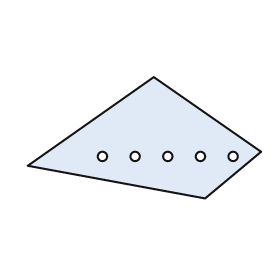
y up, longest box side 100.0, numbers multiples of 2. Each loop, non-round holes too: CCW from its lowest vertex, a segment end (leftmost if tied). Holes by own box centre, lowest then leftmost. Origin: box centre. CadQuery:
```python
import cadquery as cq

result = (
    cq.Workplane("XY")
    .moveTo(26.0, -26.0)
    .lineTo(50.0, -6.0)
    .lineTo(4.0, 26.0)
    .lineTo(-50.0, -12.0)
    .close()
    .moveTo(-18.0, -8.0)
    .circle(2.0)
    .moveTo(-4.0, -8.0)
    .circle(2.0)
    .moveTo(10.0, -8.0)
    .circle(2.0)
    .moveTo(24.0, -8.0)
    .circle(2.0)
    .moveTo(38.0, -8.0)
    .circle(2.0)
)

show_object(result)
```